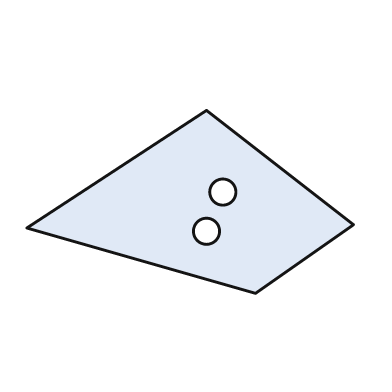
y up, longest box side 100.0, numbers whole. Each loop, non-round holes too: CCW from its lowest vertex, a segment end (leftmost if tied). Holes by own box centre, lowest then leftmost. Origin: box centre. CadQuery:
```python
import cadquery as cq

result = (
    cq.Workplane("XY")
    .moveTo(20.0, -28.0)
    .lineTo(50.0, -7.0)
    .lineTo(5.0, 28.0)
    .lineTo(-50.0, -8.0)
    .close()
    .moveTo(5.0, -9.0)
    .circle(4.0)
    .moveTo(10.0, 3.0)
    .circle(4.0)
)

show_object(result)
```